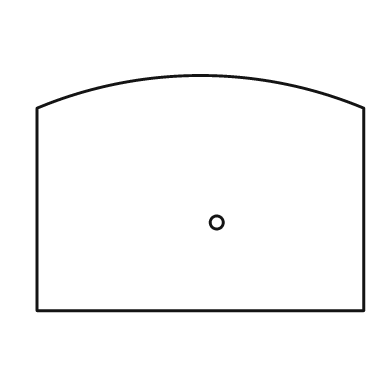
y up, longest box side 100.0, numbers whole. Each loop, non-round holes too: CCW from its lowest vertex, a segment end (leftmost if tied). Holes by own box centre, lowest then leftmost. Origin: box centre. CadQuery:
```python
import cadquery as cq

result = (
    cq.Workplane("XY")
    .moveTo(-50.0, -36.0)
    .lineTo(50.0, -36.0)
    .lineTo(50.0, 26.0)
    .threePointArc((0.0, 36.0), (-50.0, 26.0))
    .close()
    .moveTo(5.0, -9.0)
    .circle(2.0)
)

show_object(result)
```